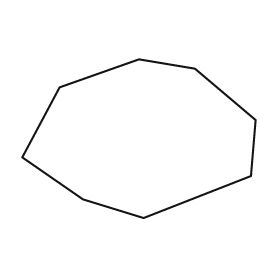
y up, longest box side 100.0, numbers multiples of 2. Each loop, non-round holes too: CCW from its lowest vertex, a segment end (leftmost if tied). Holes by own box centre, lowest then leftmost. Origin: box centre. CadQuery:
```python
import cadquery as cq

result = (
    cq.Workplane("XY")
    .moveTo(2.0, -34.0)
    .lineTo(48.0, -16.0)
    .lineTo(50.0, 8.0)
    .lineTo(24.0, 30.0)
    .lineTo(0.0, 34.0)
    .lineTo(-34.0, 22.0)
    .lineTo(-50.0, -8.0)
    .lineTo(-24.0, -26.0)
    .close()
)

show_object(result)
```